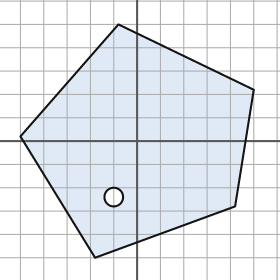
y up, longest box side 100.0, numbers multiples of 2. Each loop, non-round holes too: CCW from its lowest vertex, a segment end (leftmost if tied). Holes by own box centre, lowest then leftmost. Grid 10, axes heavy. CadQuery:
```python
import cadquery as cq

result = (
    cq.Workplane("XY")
    .moveTo(-18.0, -50.0)
    .lineTo(42.0, -28.0)
    .lineTo(50.0, 22.0)
    .lineTo(-8.0, 50.0)
    .lineTo(-50.0, 2.0)
    .close()
    .moveTo(-10.0, -24.0)
    .circle(4.0)
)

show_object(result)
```